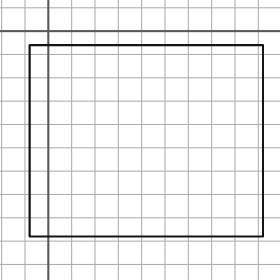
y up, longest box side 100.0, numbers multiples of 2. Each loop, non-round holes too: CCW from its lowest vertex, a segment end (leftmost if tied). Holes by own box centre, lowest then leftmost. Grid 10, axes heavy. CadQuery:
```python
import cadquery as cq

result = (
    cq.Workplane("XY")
    .moveTo(-8.0, -88.0)
    .lineTo(92.0, -88.0)
    .lineTo(92.0, -6.0)
    .lineTo(-8.0, -6.0)
    .close()
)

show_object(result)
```